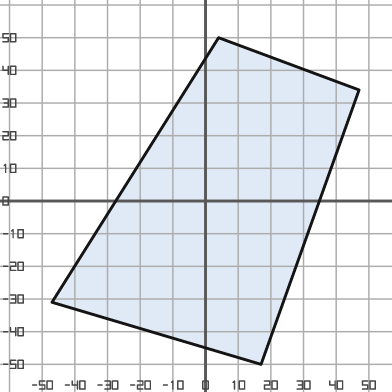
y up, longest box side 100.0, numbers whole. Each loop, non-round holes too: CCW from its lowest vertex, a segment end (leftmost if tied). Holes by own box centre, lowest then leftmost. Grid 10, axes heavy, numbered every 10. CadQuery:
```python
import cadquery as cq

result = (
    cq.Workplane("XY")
    .moveTo(17.0, -50.0)
    .lineTo(47.0, 34.0)
    .lineTo(4.0, 50.0)
    .lineTo(-47.0, -31.0)
    .close()
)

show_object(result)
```